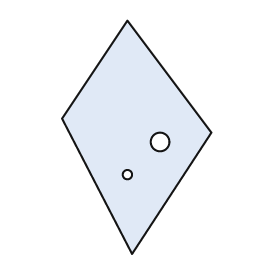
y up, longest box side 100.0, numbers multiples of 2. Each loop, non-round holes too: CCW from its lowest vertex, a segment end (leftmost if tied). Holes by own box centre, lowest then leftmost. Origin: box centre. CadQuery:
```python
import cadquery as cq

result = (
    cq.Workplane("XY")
    .moveTo(-2.0, -50.0)
    .lineTo(32.0, 2.0)
    .lineTo(-4.0, 50.0)
    .lineTo(-32.0, 8.0)
    .close()
    .moveTo(-4.0, -16.0)
    .circle(2.0)
    .moveTo(10.0, -2.0)
    .circle(4.0)
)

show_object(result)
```